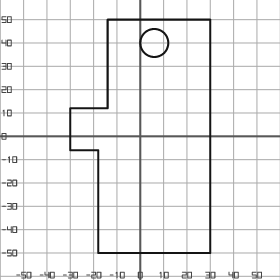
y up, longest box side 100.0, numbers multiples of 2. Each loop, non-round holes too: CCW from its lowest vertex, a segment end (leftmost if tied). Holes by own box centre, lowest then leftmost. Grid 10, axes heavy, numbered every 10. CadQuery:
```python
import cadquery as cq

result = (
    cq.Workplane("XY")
    .moveTo(-18.0, -50.0)
    .lineTo(30.0, -50.0)
    .lineTo(30.0, 50.0)
    .lineTo(-14.0, 50.0)
    .lineTo(-14.0, 12.0)
    .lineTo(-30.0, 12.0)
    .lineTo(-30.0, -6.0)
    .lineTo(-18.0, -6.0)
    .close()
    .moveTo(6.0, 40.0)
    .circle(6.0)
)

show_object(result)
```